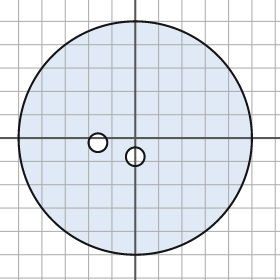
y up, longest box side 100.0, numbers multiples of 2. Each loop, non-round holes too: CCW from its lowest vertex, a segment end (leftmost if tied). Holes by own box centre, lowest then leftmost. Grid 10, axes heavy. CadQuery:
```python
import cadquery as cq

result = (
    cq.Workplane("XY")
    .moveTo(0.0, 0.0)
    .circle(50.0)
    .moveTo(0.0, -8.0)
    .circle(4.0)
    .moveTo(-16.0, -2.0)
    .circle(4.0)
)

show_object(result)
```